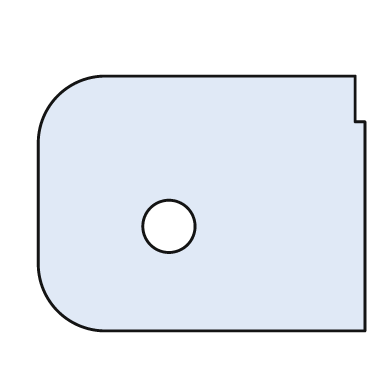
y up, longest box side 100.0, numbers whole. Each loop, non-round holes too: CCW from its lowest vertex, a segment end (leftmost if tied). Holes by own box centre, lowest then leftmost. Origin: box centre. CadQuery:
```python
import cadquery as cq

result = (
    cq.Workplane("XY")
    .moveTo(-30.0, -39.0)
    .lineTo(50.0, -39.0)
    .lineTo(50.0, 25.0)
    .lineTo(47.0, 25.0)
    .lineTo(47.0, 39.0)
    .lineTo(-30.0, 39.0)
    .threePointArc((-44.0, 33.0), (-50.0, 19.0))
    .lineTo(-50.0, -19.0)
    .threePointArc((-44.0, -33.0), (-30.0, -39.0))
    .close()
    .moveTo(-10.0, -7.0)
    .circle(8.0)
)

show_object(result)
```